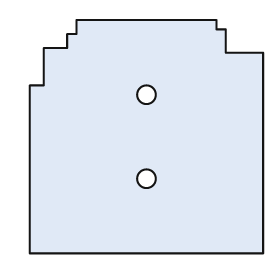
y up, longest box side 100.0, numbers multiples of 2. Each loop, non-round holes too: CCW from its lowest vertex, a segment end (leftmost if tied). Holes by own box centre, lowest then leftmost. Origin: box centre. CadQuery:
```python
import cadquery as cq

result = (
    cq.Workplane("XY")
    .moveTo(-50.0, -50.0)
    .lineTo(50.0, -50.0)
    .lineTo(50.0, 36.0)
    .lineTo(34.0, 36.0)
    .lineTo(34.0, 46.0)
    .lineTo(30.0, 46.0)
    .lineTo(30.0, 50.0)
    .lineTo(-30.0, 50.0)
    .lineTo(-30.0, 44.0)
    .lineTo(-34.0, 44.0)
    .lineTo(-34.0, 38.0)
    .lineTo(-44.0, 38.0)
    .lineTo(-44.0, 22.0)
    .lineTo(-50.0, 22.0)
    .close()
    .moveTo(0.0, -18.0)
    .circle(4.0)
    .moveTo(0.0, 18.0)
    .circle(4.0)
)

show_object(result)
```